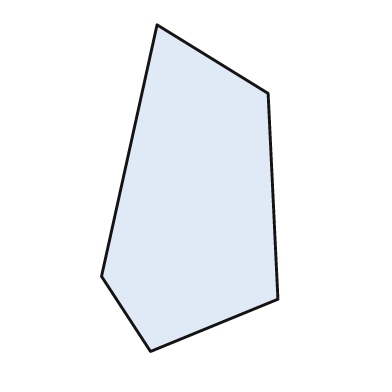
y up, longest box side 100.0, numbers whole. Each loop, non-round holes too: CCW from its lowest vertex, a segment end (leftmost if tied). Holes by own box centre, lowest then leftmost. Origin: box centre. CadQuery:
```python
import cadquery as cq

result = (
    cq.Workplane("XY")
    .moveTo(-12.0, -50.0)
    .lineTo(27.0, -34.0)
    .lineTo(24.0, 29.0)
    .lineTo(-10.0, 50.0)
    .lineTo(-27.0, -27.0)
    .close()
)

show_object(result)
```